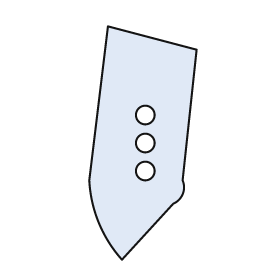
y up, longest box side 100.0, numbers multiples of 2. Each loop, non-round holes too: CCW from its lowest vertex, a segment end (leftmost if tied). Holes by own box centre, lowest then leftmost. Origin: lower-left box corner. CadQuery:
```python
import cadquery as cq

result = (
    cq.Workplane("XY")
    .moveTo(14.0, 0.0)
    .lineTo(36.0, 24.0)
    .threePointArc((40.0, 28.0), (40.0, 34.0))
    .lineTo(46.0, 90.0)
    .lineTo(8.0, 100.0)
    .lineTo(0.0, 34.0)
    .threePointArc((4.0, 16.0), (14.0, 0.0))
    .close()
    .moveTo(24.0, 38.0)
    .circle(4.0)
    .moveTo(24.0, 50.0)
    .circle(4.0)
    .moveTo(24.0, 62.0)
    .circle(4.0)
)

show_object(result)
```